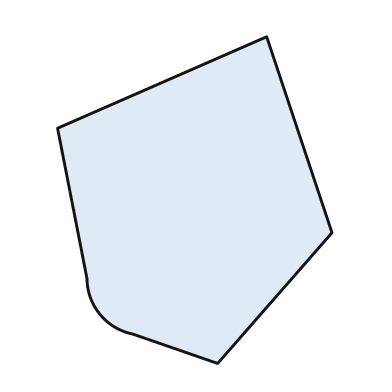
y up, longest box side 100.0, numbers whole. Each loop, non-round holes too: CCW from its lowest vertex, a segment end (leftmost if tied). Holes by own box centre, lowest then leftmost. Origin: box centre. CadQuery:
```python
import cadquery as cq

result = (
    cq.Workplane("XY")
    .moveTo(7.0, -50.0)
    .lineTo(42.0, -10.0)
    .lineTo(22.0, 50.0)
    .lineTo(-42.0, 22.0)
    .lineTo(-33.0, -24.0)
    .threePointArc((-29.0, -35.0), (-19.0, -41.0))
    .close()
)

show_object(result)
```